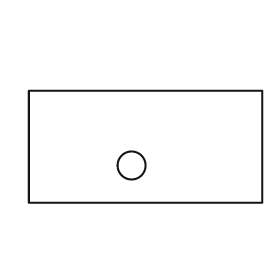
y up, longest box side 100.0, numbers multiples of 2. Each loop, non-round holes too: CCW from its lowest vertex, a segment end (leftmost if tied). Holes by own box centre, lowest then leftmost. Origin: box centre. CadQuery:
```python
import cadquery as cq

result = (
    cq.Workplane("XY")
    .moveTo(-50.0, -24.0)
    .lineTo(50.0, -24.0)
    .lineTo(50.0, 24.0)
    .lineTo(-50.0, 24.0)
    .close()
    .moveTo(-6.0, -8.0)
    .circle(6.0)
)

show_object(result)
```